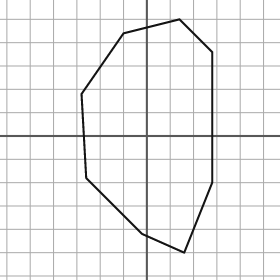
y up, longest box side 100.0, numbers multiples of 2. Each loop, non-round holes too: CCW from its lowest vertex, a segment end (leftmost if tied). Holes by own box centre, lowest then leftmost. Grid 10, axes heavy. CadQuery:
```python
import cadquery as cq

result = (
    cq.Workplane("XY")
    .moveTo(16.0, -50.0)
    .lineTo(28.0, -20.0)
    .lineTo(28.0, 36.0)
    .lineTo(14.0, 50.0)
    .lineTo(-10.0, 44.0)
    .lineTo(-28.0, 18.0)
    .lineTo(-26.0, -18.0)
    .lineTo(-2.0, -42.0)
    .close()
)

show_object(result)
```